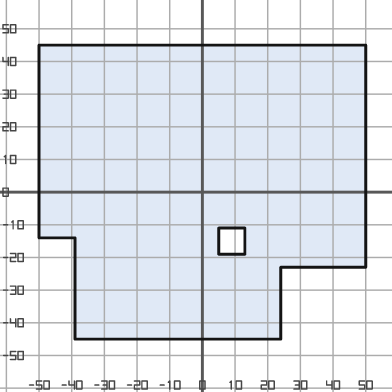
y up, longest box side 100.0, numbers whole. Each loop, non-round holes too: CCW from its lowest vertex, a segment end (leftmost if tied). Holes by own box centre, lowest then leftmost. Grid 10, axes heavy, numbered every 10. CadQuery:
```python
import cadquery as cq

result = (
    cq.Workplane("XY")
    .moveTo(-39.0, -45.0)
    .lineTo(24.0, -45.0)
    .lineTo(24.0, -23.0)
    .lineTo(50.0, -23.0)
    .lineTo(50.0, 45.0)
    .lineTo(-50.0, 45.0)
    .lineTo(-50.0, -14.0)
    .lineTo(-39.0, -14.0)
    .close()
    .moveTo(5.0, -19.0)
    .lineTo(13.0, -19.0)
    .lineTo(13.0, -11.0)
    .lineTo(5.0, -11.0)
    .close()
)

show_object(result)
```